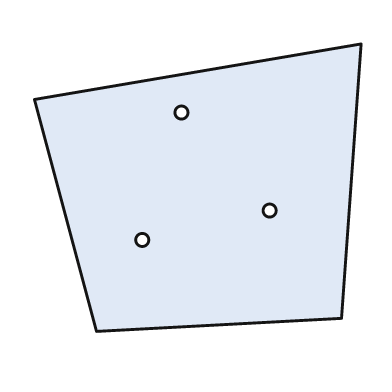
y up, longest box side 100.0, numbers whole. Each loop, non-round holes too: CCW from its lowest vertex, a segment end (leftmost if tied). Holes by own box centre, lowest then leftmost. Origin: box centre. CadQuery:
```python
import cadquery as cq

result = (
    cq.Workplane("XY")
    .moveTo(-31.0, -44.0)
    .lineTo(44.0, -40.0)
    .lineTo(50.0, 44.0)
    .lineTo(-50.0, 27.0)
    .close()
    .moveTo(-17.0, -16.0)
    .circle(2.0)
    .moveTo(22.0, -7.0)
    .circle(2.0)
    .moveTo(-5.0, 23.0)
    .circle(2.0)
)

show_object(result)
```